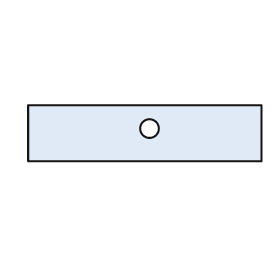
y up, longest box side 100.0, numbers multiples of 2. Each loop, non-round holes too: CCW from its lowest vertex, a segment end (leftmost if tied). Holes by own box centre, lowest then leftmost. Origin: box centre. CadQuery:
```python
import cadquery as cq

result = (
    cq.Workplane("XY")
    .moveTo(-50.0, -12.0)
    .lineTo(50.0, -12.0)
    .lineTo(50.0, 12.0)
    .lineTo(-50.0, 12.0)
    .close()
    .moveTo(2.0, 2.0)
    .circle(4.0)
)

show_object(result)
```